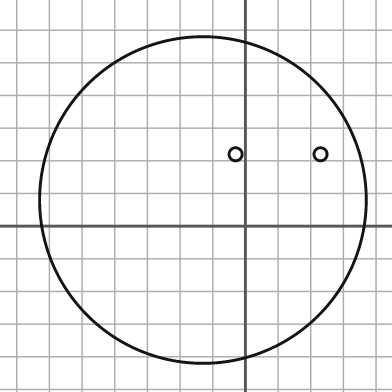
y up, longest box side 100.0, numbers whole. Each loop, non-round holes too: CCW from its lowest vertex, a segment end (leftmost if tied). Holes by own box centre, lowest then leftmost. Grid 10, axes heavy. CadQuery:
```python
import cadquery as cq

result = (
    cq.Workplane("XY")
    .moveTo(-13.0, 8.0)
    .circle(50.0)
    .moveTo(-3.0, 22.0)
    .circle(2.0)
    .moveTo(23.0, 22.0)
    .circle(2.0)
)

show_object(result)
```